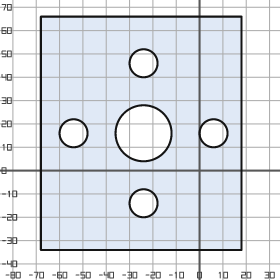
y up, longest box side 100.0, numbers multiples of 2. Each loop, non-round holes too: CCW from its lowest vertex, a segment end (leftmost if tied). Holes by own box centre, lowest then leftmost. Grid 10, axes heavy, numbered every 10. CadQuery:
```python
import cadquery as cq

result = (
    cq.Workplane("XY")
    .moveTo(-68.0, -34.0)
    .lineTo(18.0, -34.0)
    .lineTo(18.0, 66.0)
    .lineTo(-68.0, 66.0)
    .close()
    .moveTo(-24.0, -14.0)
    .circle(6.0)
    .moveTo(-54.0, 16.0)
    .circle(6.0)
    .moveTo(-24.0, 16.0)
    .circle(12.0)
    .moveTo(6.0, 16.0)
    .circle(6.0)
    .moveTo(-24.0, 46.0)
    .circle(6.0)
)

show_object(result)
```